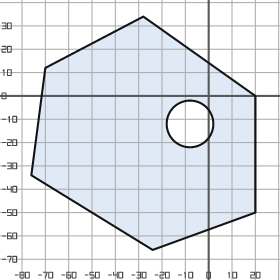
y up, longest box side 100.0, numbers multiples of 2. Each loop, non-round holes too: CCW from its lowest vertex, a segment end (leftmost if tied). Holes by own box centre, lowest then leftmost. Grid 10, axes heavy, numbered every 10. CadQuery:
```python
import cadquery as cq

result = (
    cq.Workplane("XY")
    .moveTo(-24.0, -66.0)
    .lineTo(20.0, -50.0)
    .lineTo(20.0, 0.0)
    .lineTo(-28.0, 34.0)
    .lineTo(-70.0, 12.0)
    .lineTo(-76.0, -34.0)
    .close()
    .moveTo(-8.0, -12.0)
    .circle(10.0)
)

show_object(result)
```